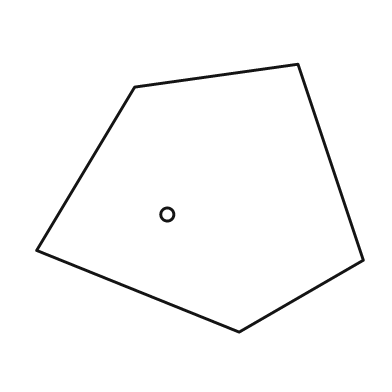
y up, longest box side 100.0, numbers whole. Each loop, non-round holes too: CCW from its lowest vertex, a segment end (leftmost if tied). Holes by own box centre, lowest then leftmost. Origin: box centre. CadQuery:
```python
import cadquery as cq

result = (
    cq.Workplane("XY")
    .moveTo(12.0, -41.0)
    .lineTo(50.0, -19.0)
    .lineTo(30.0, 41.0)
    .lineTo(-20.0, 34.0)
    .lineTo(-50.0, -16.0)
    .close()
    .moveTo(-10.0, -5.0)
    .circle(2.0)
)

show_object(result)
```